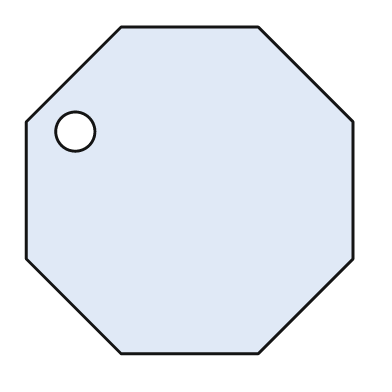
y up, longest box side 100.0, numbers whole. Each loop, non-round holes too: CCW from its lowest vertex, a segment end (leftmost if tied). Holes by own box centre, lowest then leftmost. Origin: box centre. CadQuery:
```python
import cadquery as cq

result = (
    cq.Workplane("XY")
    .moveTo(-21.0, -50.0)
    .lineTo(21.0, -50.0)
    .lineTo(50.0, -21.0)
    .lineTo(50.0, 21.0)
    .lineTo(21.0, 50.0)
    .lineTo(-21.0, 50.0)
    .lineTo(-50.0, 21.0)
    .lineTo(-50.0, -21.0)
    .close()
    .moveTo(-35.0, 18.0)
    .circle(6.0)
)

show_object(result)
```